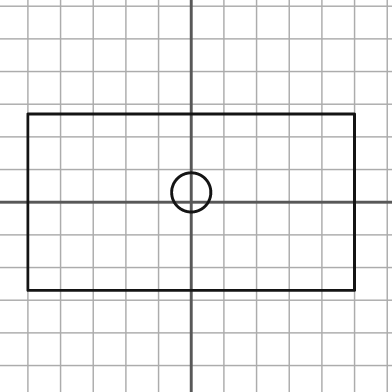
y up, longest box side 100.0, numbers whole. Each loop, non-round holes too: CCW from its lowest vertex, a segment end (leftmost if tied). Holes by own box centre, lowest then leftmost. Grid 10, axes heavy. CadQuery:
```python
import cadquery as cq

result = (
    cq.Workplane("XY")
    .moveTo(-50.0, -27.0)
    .lineTo(50.0, -27.0)
    .lineTo(50.0, 27.0)
    .lineTo(-50.0, 27.0)
    .close()
    .moveTo(0.0, 3.0)
    .circle(6.0)
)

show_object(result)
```